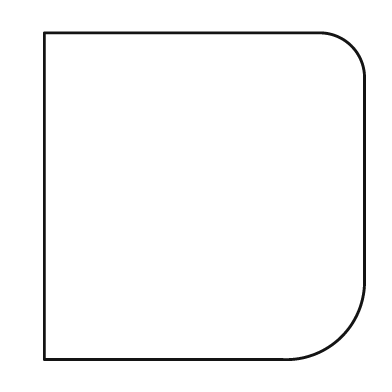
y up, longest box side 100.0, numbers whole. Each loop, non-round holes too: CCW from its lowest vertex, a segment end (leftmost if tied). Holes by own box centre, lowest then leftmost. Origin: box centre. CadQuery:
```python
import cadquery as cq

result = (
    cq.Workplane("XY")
    .moveTo(-49.0, -50.0)
    .lineTo(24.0, -50.0)
    .threePointArc((42.0, -43.0), (49.0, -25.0))
    .lineTo(49.0, 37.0)
    .threePointArc((45.0, 46.0), (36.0, 50.0))
    .lineTo(-49.0, 50.0)
    .close()
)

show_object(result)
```